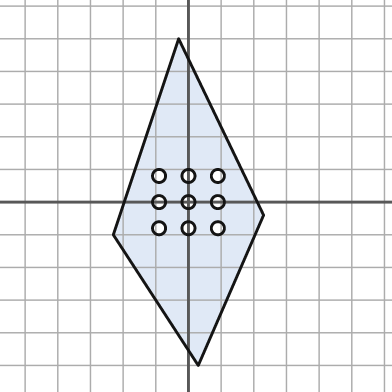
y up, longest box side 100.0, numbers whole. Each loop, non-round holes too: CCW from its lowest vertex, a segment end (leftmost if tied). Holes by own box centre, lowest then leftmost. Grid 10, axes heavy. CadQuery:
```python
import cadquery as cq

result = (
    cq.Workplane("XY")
    .moveTo(3.0, -50.0)
    .lineTo(23.0, -4.0)
    .lineTo(-3.0, 50.0)
    .lineTo(-23.0, -10.0)
    .close()
    .moveTo(-9.0, -8.0)
    .circle(2.0)
    .moveTo(0.0, -8.0)
    .circle(2.0)
    .moveTo(9.0, -8.0)
    .circle(2.0)
    .moveTo(-9.0, 0.0)
    .circle(2.0)
    .moveTo(0.0, 0.0)
    .circle(2.0)
    .moveTo(9.0, 0.0)
    .circle(2.0)
    .moveTo(-9.0, 8.0)
    .circle(2.0)
    .moveTo(0.0, 8.0)
    .circle(2.0)
    .moveTo(9.0, 8.0)
    .circle(2.0)
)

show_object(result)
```